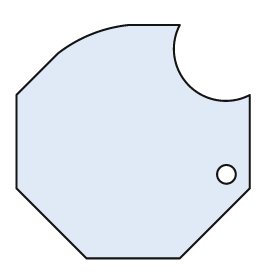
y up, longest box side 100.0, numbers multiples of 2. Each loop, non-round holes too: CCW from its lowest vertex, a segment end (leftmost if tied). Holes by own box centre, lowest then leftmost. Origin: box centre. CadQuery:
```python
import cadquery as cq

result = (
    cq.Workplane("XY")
    .moveTo(-20.0, -50.0)
    .lineTo(20.0, -50.0)
    .lineTo(50.0, -20.0)
    .lineTo(50.0, 20.0)
    .threePointArc((24.0, 24.0), (20.0, 50.0))
    .lineTo(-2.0, 50.0)
    .threePointArc((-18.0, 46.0), (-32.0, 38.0))
    .lineTo(-50.0, 20.0)
    .lineTo(-50.0, -20.0)
    .close()
    .moveTo(40.0, -14.0)
    .circle(4.0)
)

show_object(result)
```